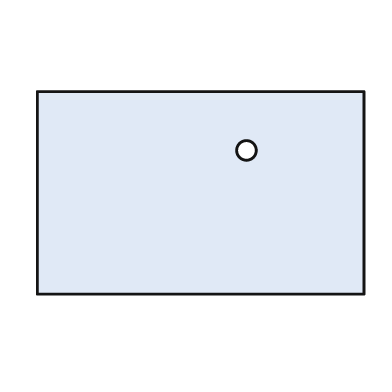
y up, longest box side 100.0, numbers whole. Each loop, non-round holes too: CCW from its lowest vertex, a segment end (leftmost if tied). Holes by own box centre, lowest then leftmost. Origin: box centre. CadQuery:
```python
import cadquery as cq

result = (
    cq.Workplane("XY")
    .moveTo(-50.0, -31.0)
    .lineTo(50.0, -31.0)
    .lineTo(50.0, 31.0)
    .lineTo(-50.0, 31.0)
    .close()
    .moveTo(14.0, 13.0)
    .circle(3.0)
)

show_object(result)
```